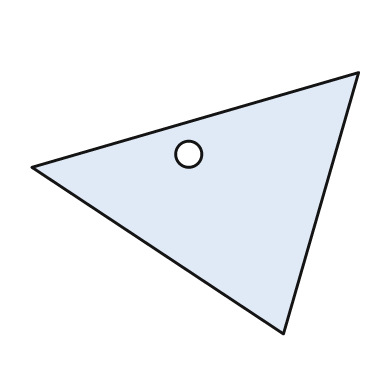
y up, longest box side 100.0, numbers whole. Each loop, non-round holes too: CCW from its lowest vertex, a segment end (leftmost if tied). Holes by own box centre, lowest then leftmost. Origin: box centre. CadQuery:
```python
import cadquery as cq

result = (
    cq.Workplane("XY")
    .moveTo(27.0, -40.0)
    .lineTo(50.0, 40.0)
    .lineTo(-50.0, 11.0)
    .close()
    .moveTo(-2.0, 15.0)
    .circle(4.0)
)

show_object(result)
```